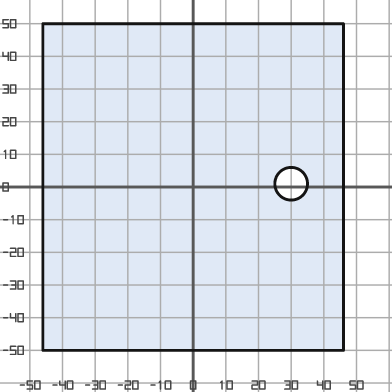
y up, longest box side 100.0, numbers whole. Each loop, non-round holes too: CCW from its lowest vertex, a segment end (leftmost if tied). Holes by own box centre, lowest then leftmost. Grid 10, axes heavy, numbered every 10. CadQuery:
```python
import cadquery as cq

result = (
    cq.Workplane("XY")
    .moveTo(-46.0, -50.0)
    .lineTo(46.0, -50.0)
    .lineTo(46.0, 50.0)
    .lineTo(-46.0, 50.0)
    .close()
    .moveTo(30.0, 1.0)
    .circle(5.0)
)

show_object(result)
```